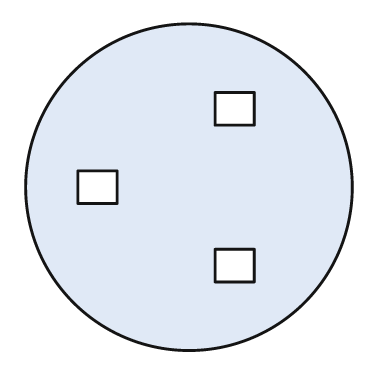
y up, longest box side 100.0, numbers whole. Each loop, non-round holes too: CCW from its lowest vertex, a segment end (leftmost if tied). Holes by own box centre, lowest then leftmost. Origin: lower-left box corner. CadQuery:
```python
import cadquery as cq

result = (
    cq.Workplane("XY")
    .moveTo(50.0, 50.0)
    .circle(50.0)
    .moveTo(58.0, 21.0)
    .lineTo(70.0, 21.0)
    .lineTo(70.0, 31.0)
    .lineTo(58.0, 31.0)
    .close()
    .moveTo(16.0, 45.0)
    .lineTo(28.0, 45.0)
    .lineTo(28.0, 55.0)
    .lineTo(16.0, 55.0)
    .close()
    .moveTo(58.0, 69.0)
    .lineTo(70.0, 69.0)
    .lineTo(70.0, 79.0)
    .lineTo(58.0, 79.0)
    .close()
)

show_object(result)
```